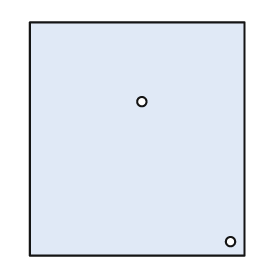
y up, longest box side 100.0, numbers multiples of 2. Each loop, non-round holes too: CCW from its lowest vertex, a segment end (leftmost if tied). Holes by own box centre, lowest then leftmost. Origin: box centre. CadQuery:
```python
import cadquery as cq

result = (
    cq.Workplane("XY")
    .moveTo(-46.0, -50.0)
    .lineTo(46.0, -50.0)
    .lineTo(46.0, 50.0)
    .lineTo(-46.0, 50.0)
    .close()
    .moveTo(40.0, -44.0)
    .circle(2.0)
    .moveTo(2.0, 16.0)
    .circle(2.0)
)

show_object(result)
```